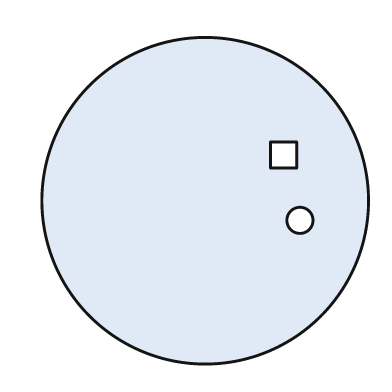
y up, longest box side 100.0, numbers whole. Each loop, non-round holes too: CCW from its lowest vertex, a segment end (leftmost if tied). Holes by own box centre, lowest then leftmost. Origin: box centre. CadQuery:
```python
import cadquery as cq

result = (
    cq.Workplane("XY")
    .moveTo(0.0, 0.0)
    .circle(50.0)
    .moveTo(29.0, -6.0)
    .circle(4.0)
    .moveTo(20.0, 10.0)
    .lineTo(28.0, 10.0)
    .lineTo(28.0, 18.0)
    .lineTo(20.0, 18.0)
    .close()
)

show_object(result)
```